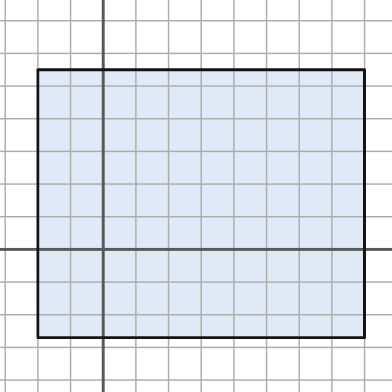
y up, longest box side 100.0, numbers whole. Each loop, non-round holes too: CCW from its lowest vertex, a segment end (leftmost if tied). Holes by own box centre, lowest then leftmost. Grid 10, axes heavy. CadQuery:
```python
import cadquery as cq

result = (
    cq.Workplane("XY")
    .moveTo(-20.0, -27.0)
    .lineTo(80.0, -27.0)
    .lineTo(80.0, 55.0)
    .lineTo(-20.0, 55.0)
    .close()
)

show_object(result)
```